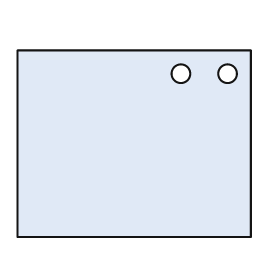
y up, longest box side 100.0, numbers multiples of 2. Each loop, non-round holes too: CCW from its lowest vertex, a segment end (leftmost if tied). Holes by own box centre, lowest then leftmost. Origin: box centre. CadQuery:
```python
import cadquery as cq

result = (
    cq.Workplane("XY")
    .moveTo(-50.0, -40.0)
    .lineTo(50.0, -40.0)
    .lineTo(50.0, 40.0)
    .lineTo(-50.0, 40.0)
    .close()
    .moveTo(20.0, 30.0)
    .circle(4.0)
    .moveTo(40.0, 30.0)
    .circle(4.0)
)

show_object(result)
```